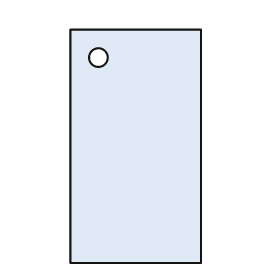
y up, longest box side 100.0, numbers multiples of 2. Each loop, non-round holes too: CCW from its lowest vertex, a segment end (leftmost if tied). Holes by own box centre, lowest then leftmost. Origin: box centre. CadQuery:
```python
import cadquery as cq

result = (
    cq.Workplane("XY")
    .moveTo(-28.0, -50.0)
    .lineTo(28.0, -50.0)
    .lineTo(28.0, 50.0)
    .lineTo(-28.0, 50.0)
    .close()
    .moveTo(-16.0, 38.0)
    .circle(4.0)
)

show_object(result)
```